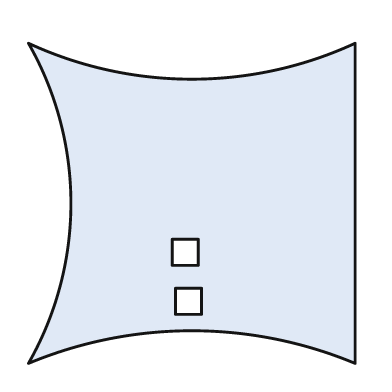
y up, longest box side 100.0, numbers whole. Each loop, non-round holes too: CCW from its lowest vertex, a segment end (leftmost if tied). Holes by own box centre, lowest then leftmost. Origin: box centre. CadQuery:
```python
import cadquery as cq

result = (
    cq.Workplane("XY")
    .moveTo(-50.0, -49.0)
    .threePointArc((0.0, -39.0), (50.0, -49.0))
    .lineTo(50.0, 49.0)
    .threePointArc((0.0, 38.0), (-50.0, 49.0))
    .threePointArc((-37.0, 0.0), (-50.0, -49.0))
    .close()
    .moveTo(-5.0, -34.0)
    .lineTo(3.0, -34.0)
    .lineTo(3.0, -26.0)
    .lineTo(-5.0, -26.0)
    .close()
    .moveTo(-6.0, -19.0)
    .lineTo(2.0, -19.0)
    .lineTo(2.0, -11.0)
    .lineTo(-6.0, -11.0)
    .close()
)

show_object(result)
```